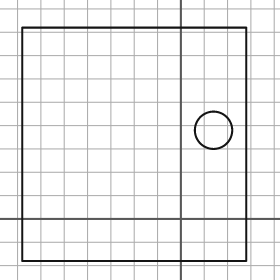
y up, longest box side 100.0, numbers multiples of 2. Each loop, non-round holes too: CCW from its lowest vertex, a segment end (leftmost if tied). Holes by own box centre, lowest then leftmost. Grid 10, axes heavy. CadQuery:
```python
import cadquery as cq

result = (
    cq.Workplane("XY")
    .moveTo(-68.0, -18.0)
    .lineTo(28.0, -18.0)
    .lineTo(28.0, 82.0)
    .lineTo(-68.0, 82.0)
    .close()
    .moveTo(14.0, 38.0)
    .circle(8.0)
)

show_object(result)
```